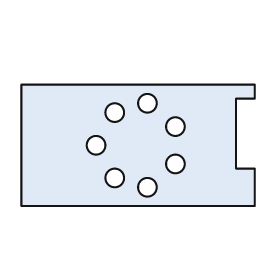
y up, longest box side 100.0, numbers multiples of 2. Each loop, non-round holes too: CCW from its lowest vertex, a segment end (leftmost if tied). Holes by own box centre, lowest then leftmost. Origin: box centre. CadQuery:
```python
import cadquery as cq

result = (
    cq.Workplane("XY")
    .moveTo(-50.0, -26.0)
    .lineTo(50.0, -26.0)
    .lineTo(50.0, -10.0)
    .lineTo(42.0, -10.0)
    .lineTo(42.0, 20.0)
    .lineTo(50.0, 20.0)
    .lineTo(50.0, 26.0)
    .lineTo(-50.0, 26.0)
    .close()
    .moveTo(4.0, -18.0)
    .circle(4.0)
    .moveTo(-10.0, -14.0)
    .circle(4.0)
    .moveTo(16.0, -8.0)
    .circle(4.0)
    .moveTo(-18.0, 0.0)
    .circle(4.0)
    .moveTo(16.0, 8.0)
    .circle(4.0)
    .moveTo(-10.0, 14.0)
    .circle(4.0)
    .moveTo(4.0, 18.0)
    .circle(4.0)
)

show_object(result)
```